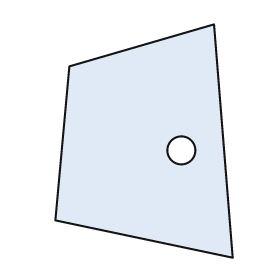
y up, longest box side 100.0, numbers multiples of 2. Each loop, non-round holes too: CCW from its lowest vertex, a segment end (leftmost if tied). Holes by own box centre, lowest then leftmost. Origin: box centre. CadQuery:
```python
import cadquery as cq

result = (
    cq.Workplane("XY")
    .moveTo(38.0, -50.0)
    .lineTo(30.0, 50.0)
    .lineTo(-32.0, 32.0)
    .lineTo(-38.0, -34.0)
    .close()
    .moveTo(16.0, -4.0)
    .circle(6.0)
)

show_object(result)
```